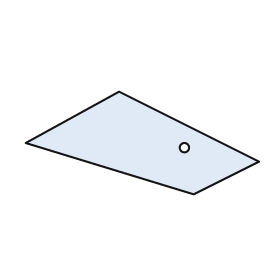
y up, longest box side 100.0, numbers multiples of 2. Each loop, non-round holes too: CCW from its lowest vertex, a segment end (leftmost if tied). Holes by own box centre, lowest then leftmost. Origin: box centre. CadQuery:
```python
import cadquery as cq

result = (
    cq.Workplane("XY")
    .moveTo(22.0, -22.0)
    .lineTo(50.0, -8.0)
    .lineTo(-10.0, 22.0)
    .lineTo(-50.0, 0.0)
    .close()
    .moveTo(18.0, -2.0)
    .circle(2.0)
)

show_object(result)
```